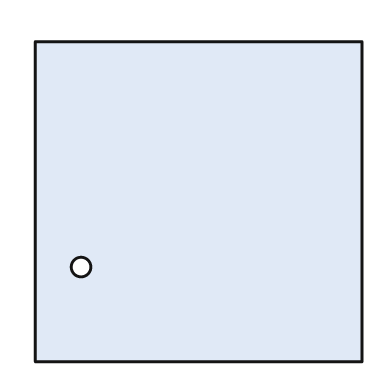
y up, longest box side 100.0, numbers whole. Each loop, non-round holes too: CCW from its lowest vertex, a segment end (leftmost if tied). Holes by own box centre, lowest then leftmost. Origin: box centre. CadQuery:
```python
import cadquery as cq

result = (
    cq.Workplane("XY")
    .moveTo(-50.0, -49.0)
    .lineTo(50.0, -49.0)
    .lineTo(50.0, 49.0)
    .lineTo(-50.0, 49.0)
    .close()
    .moveTo(-36.0, -20.0)
    .circle(3.0)
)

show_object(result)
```